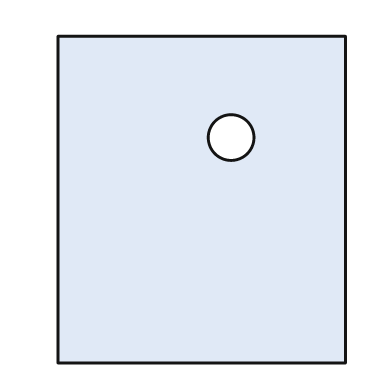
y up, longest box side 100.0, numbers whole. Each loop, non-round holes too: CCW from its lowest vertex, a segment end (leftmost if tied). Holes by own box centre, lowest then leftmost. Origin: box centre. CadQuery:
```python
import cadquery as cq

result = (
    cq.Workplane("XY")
    .moveTo(-44.0, -50.0)
    .lineTo(44.0, -50.0)
    .lineTo(44.0, 50.0)
    .lineTo(-44.0, 50.0)
    .close()
    .moveTo(9.0, 19.0)
    .circle(7.0)
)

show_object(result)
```